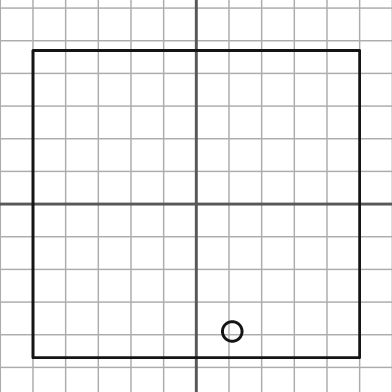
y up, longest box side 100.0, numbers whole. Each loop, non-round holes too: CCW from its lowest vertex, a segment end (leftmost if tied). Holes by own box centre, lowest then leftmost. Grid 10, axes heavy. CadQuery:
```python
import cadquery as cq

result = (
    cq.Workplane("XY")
    .moveTo(-50.0, -47.0)
    .lineTo(50.0, -47.0)
    .lineTo(50.0, 47.0)
    .lineTo(-50.0, 47.0)
    .close()
    .moveTo(11.0, -39.0)
    .circle(3.0)
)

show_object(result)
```